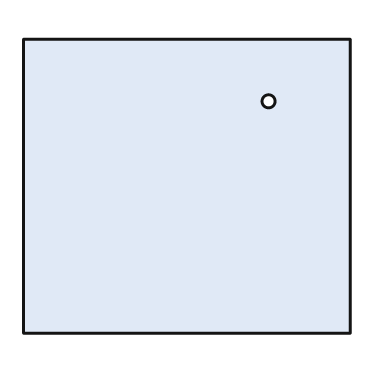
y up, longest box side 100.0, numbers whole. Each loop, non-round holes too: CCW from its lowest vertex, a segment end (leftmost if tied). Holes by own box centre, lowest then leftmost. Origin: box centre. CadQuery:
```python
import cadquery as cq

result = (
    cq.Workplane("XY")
    .moveTo(-50.0, -45.0)
    .lineTo(50.0, -45.0)
    .lineTo(50.0, 45.0)
    .lineTo(-50.0, 45.0)
    .close()
    .moveTo(25.0, 26.0)
    .circle(2.0)
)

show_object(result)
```